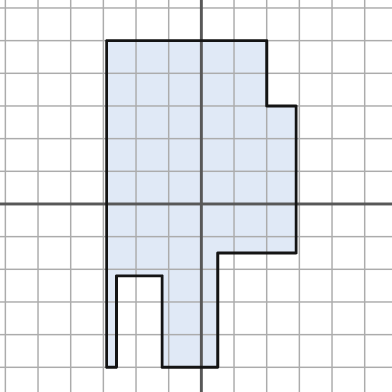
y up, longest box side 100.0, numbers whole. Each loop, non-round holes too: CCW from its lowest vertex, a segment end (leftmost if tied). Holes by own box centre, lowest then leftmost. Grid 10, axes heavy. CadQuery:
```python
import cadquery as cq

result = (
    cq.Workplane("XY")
    .moveTo(-29.0, -50.0)
    .lineTo(-26.0, -50.0)
    .lineTo(-26.0, -22.0)
    .lineTo(-12.0, -22.0)
    .lineTo(-12.0, -50.0)
    .lineTo(5.0, -50.0)
    .lineTo(5.0, -15.0)
    .lineTo(29.0, -15.0)
    .lineTo(29.0, 30.0)
    .lineTo(20.0, 30.0)
    .lineTo(20.0, 50.0)
    .lineTo(-29.0, 50.0)
    .close()
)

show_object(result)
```